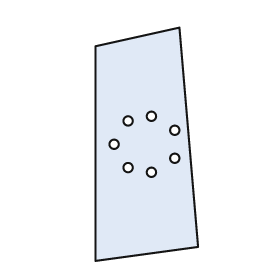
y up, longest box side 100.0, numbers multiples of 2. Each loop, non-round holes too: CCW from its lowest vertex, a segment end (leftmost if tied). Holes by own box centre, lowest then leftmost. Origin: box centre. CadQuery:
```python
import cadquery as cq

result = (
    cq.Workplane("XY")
    .moveTo(-22.0, -50.0)
    .lineTo(22.0, -44.0)
    .lineTo(14.0, 50.0)
    .lineTo(-22.0, 42.0)
    .close()
    .moveTo(2.0, -12.0)
    .circle(2.0)
    .moveTo(-8.0, -10.0)
    .circle(2.0)
    .moveTo(12.0, -6.0)
    .circle(2.0)
    .moveTo(-14.0, 0.0)
    .circle(2.0)
    .moveTo(12.0, 6.0)
    .circle(2.0)
    .moveTo(-8.0, 10.0)
    .circle(2.0)
    .moveTo(2.0, 12.0)
    .circle(2.0)
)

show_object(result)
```